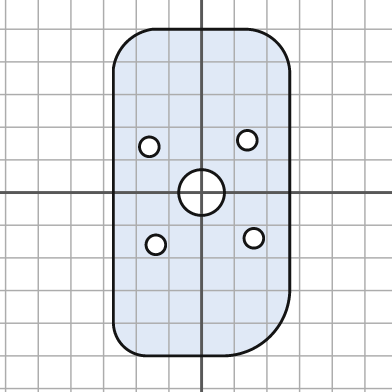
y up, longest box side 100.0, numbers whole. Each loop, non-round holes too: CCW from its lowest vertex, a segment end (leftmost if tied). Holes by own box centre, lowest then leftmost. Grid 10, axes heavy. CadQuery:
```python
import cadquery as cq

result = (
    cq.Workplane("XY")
    .moveTo(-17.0, -50.0)
    .lineTo(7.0, -50.0)
    .threePointArc((21.0, -44.0), (27.0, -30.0))
    .lineTo(27.0, 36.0)
    .threePointArc((23.0, 46.0), (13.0, 50.0))
    .lineTo(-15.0, 50.0)
    .threePointArc((-23.0, 46.0), (-27.0, 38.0))
    .lineTo(-27.0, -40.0)
    .threePointArc((-24.0, -47.0), (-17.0, -50.0))
    .close()
    .moveTo(-14.0, -16.0)
    .circle(3.0)
    .moveTo(16.0, -14.0)
    .circle(3.0)
    .moveTo(0.0, 0.0)
    .circle(7.0)
    .moveTo(-16.0, 14.0)
    .circle(3.0)
    .moveTo(14.0, 16.0)
    .circle(3.0)
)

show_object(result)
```